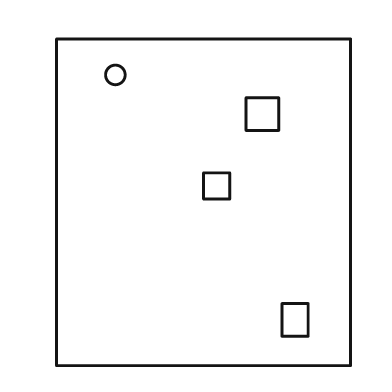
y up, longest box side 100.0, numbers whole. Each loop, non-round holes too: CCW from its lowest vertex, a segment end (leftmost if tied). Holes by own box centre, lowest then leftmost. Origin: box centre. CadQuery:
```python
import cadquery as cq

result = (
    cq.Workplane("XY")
    .moveTo(-45.0, -50.0)
    .lineTo(45.0, -50.0)
    .lineTo(45.0, 50.0)
    .lineTo(-45.0, 50.0)
    .close()
    .moveTo(24.0, -41.0)
    .lineTo(32.0, -41.0)
    .lineTo(32.0, -31.0)
    .lineTo(24.0, -31.0)
    .close()
    .moveTo(0.0, 1.0)
    .lineTo(8.0, 1.0)
    .lineTo(8.0, 9.0)
    .lineTo(0.0, 9.0)
    .close()
    .moveTo(13.0, 22.0)
    .lineTo(23.0, 22.0)
    .lineTo(23.0, 32.0)
    .lineTo(13.0, 32.0)
    .close()
    .moveTo(-27.0, 39.0)
    .circle(3.0)
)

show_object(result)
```